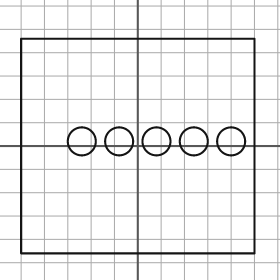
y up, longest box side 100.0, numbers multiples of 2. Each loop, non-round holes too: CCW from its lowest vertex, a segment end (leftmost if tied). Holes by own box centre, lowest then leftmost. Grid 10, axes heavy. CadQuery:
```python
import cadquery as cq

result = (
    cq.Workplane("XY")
    .moveTo(-50.0, -46.0)
    .lineTo(50.0, -46.0)
    .lineTo(50.0, 46.0)
    .lineTo(-50.0, 46.0)
    .close()
    .moveTo(-24.0, 2.0)
    .circle(6.0)
    .moveTo(-8.0, 2.0)
    .circle(6.0)
    .moveTo(8.0, 2.0)
    .circle(6.0)
    .moveTo(24.0, 2.0)
    .circle(6.0)
    .moveTo(40.0, 2.0)
    .circle(6.0)
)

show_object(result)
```